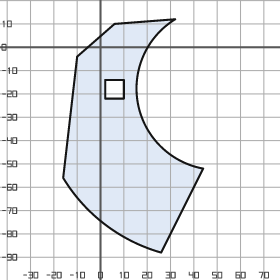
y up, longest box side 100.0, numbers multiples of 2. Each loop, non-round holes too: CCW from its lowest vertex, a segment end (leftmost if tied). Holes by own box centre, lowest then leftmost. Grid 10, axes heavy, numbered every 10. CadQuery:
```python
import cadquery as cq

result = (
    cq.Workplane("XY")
    .moveTo(26.0, -88.0)
    .lineTo(44.0, -52.0)
    .threePointArc((16.0, -24.0), (32.0, 12.0))
    .lineTo(6.0, 10.0)
    .lineTo(-10.0, -4.0)
    .lineTo(-16.0, -56.0)
    .threePointArc((2.0, -76.0), (26.0, -88.0))
    .close()
    .moveTo(2.0, -22.0)
    .lineTo(10.0, -22.0)
    .lineTo(10.0, -14.0)
    .lineTo(2.0, -14.0)
    .close()
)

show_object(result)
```